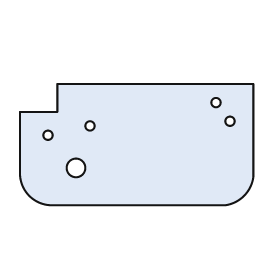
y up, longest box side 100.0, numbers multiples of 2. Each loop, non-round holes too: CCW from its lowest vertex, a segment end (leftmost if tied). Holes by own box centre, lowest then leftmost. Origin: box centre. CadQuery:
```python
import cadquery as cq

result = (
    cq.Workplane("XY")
    .moveTo(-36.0, -26.0)
    .lineTo(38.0, -26.0)
    .threePointArc((46.0, -22.0), (50.0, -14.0))
    .lineTo(50.0, 26.0)
    .lineTo(-34.0, 26.0)
    .lineTo(-34.0, 14.0)
    .lineTo(-50.0, 14.0)
    .lineTo(-50.0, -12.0)
    .threePointArc((-46.0, -22.0), (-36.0, -26.0))
    .close()
    .moveTo(-26.0, -10.0)
    .circle(4.0)
    .moveTo(-38.0, 4.0)
    .circle(2.0)
    .moveTo(-20.0, 8.0)
    .circle(2.0)
    .moveTo(40.0, 10.0)
    .circle(2.0)
    .moveTo(34.0, 18.0)
    .circle(2.0)
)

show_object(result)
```